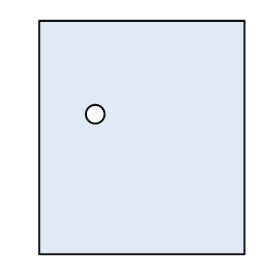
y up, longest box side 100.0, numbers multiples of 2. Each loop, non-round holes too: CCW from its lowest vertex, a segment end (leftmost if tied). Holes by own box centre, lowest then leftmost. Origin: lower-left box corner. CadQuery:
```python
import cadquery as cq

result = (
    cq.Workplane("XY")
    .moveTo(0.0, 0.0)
    .lineTo(88.0, 0.0)
    .lineTo(88.0, 100.0)
    .lineTo(0.0, 100.0)
    .close()
    .moveTo(24.0, 60.0)
    .circle(4.0)
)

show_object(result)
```